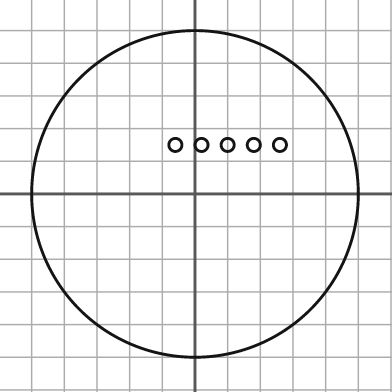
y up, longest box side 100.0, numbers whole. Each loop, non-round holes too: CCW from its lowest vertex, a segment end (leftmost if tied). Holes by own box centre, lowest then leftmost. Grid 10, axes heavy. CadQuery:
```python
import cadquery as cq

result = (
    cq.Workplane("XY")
    .moveTo(0.0, 0.0)
    .circle(50.0)
    .moveTo(-6.0, 15.0)
    .circle(2.0)
    .moveTo(2.0, 15.0)
    .circle(2.0)
    .moveTo(10.0, 15.0)
    .circle(2.0)
    .moveTo(18.0, 15.0)
    .circle(2.0)
    .moveTo(26.0, 15.0)
    .circle(2.0)
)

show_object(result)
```